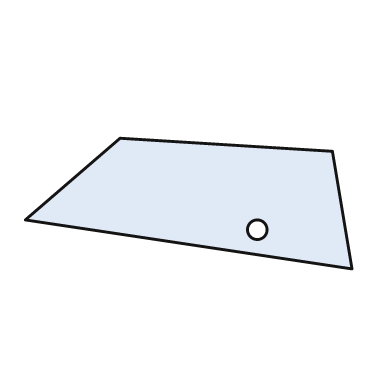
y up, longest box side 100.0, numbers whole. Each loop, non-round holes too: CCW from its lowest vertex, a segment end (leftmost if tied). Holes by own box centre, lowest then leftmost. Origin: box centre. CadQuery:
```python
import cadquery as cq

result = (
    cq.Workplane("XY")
    .moveTo(50.0, -20.0)
    .lineTo(44.0, 16.0)
    .lineTo(-21.0, 20.0)
    .lineTo(-50.0, -5.0)
    .close()
    .moveTo(21.0, -8.0)
    .circle(3.0)
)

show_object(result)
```